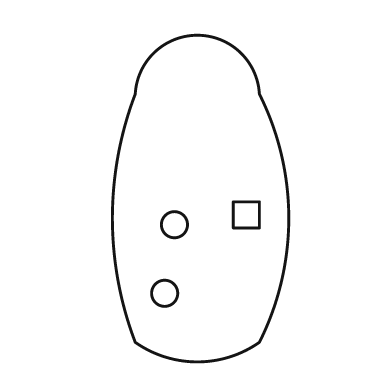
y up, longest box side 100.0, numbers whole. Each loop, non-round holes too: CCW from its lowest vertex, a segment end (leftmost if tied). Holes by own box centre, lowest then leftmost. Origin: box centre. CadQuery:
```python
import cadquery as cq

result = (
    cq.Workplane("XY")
    .moveTo(-20.0, -44.0)
    .threePointArc((-1.0, -50.0), (18.0, -44.0))
    .threePointArc((27.0, -6.0), (18.0, 32.0))
    .threePointArc((-1.0, 50.0), (-20.0, 32.0))
    .threePointArc((-27.0, -6.0), (-20.0, -44.0))
    .close()
    .moveTo(-11.0, -29.0)
    .circle(4.0)
    .moveTo(-8.0, -8.0)
    .circle(4.0)
    .moveTo(10.0, -9.0)
    .lineTo(18.0, -9.0)
    .lineTo(18.0, -1.0)
    .lineTo(10.0, -1.0)
    .close()
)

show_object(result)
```